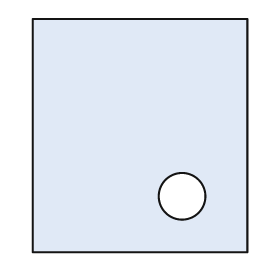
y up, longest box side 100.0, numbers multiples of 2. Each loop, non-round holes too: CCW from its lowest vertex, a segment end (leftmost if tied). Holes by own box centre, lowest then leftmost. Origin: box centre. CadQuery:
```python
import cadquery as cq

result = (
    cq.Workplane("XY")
    .moveTo(-46.0, -50.0)
    .lineTo(46.0, -50.0)
    .lineTo(46.0, 50.0)
    .lineTo(-46.0, 50.0)
    .close()
    .moveTo(18.0, -26.0)
    .circle(10.0)
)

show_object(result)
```